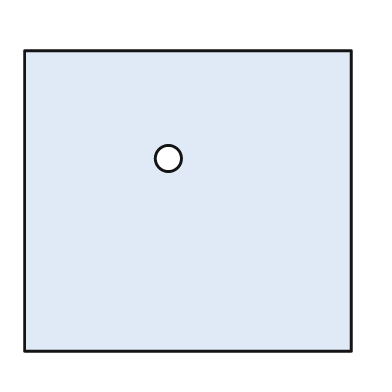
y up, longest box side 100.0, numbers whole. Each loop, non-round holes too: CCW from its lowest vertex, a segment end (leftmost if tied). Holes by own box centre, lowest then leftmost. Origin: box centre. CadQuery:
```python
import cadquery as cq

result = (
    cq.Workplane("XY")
    .moveTo(-50.0, -46.0)
    .lineTo(50.0, -46.0)
    .lineTo(50.0, 46.0)
    .lineTo(-50.0, 46.0)
    .close()
    .moveTo(-6.0, 13.0)
    .circle(4.0)
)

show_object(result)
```